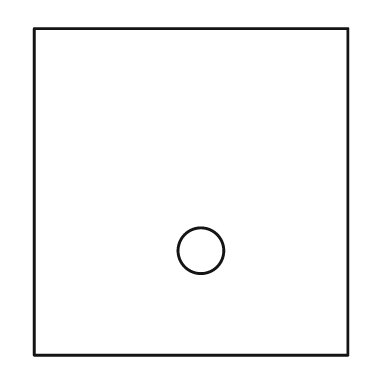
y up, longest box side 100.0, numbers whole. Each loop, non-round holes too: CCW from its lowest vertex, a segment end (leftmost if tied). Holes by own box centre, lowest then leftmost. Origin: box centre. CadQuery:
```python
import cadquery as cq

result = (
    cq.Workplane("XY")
    .moveTo(-48.0, -50.0)
    .lineTo(48.0, -50.0)
    .lineTo(48.0, 50.0)
    .lineTo(-48.0, 50.0)
    .close()
    .moveTo(3.0, -18.0)
    .circle(7.0)
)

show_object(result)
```